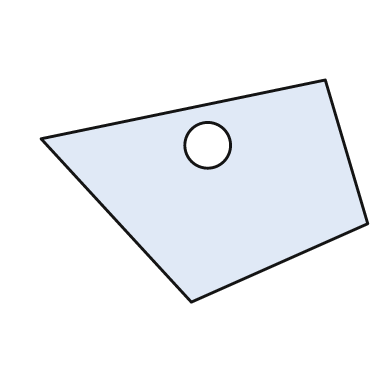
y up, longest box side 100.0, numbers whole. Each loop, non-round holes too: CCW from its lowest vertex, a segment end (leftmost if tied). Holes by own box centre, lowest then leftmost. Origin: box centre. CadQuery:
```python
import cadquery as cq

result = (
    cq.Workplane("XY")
    .moveTo(-4.0, -34.0)
    .lineTo(50.0, -10.0)
    .lineTo(37.0, 34.0)
    .lineTo(-50.0, 16.0)
    .close()
    .moveTo(1.0, 14.0)
    .circle(7.0)
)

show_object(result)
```